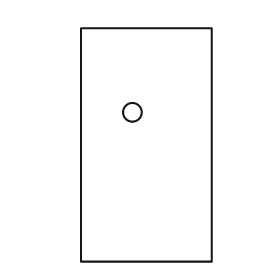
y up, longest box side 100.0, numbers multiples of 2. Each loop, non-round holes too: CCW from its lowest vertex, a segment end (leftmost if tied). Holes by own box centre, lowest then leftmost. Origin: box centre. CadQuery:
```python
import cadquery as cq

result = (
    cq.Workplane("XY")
    .moveTo(-28.0, -50.0)
    .lineTo(28.0, -50.0)
    .lineTo(28.0, 50.0)
    .lineTo(-28.0, 50.0)
    .close()
    .moveTo(-6.0, 14.0)
    .circle(4.0)
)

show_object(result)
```